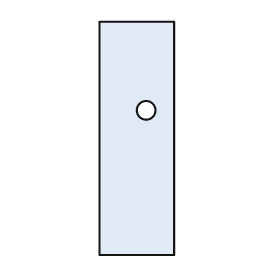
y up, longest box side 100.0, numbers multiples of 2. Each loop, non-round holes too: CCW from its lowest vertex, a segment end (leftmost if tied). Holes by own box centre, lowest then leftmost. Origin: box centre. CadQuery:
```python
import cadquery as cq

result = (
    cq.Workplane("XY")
    .moveTo(-16.0, -50.0)
    .lineTo(16.0, -50.0)
    .lineTo(16.0, 50.0)
    .lineTo(-16.0, 50.0)
    .close()
    .moveTo(4.0, 12.0)
    .circle(4.0)
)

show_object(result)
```